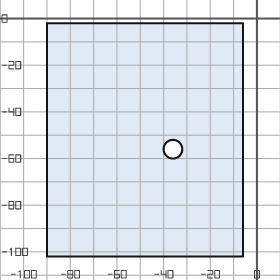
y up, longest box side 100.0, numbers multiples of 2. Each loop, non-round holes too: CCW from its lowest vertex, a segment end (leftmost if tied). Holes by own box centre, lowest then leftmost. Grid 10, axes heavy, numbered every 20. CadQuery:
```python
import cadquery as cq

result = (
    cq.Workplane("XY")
    .moveTo(-90.0, -102.0)
    .lineTo(-6.0, -102.0)
    .lineTo(-6.0, -2.0)
    .lineTo(-90.0, -2.0)
    .close()
    .moveTo(-36.0, -56.0)
    .circle(4.0)
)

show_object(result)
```